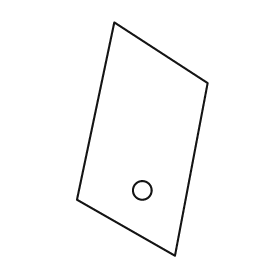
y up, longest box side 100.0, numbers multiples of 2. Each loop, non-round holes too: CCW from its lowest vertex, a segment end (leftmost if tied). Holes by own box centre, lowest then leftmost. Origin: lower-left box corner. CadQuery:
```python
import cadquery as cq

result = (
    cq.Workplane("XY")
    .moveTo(42.0, 0.0)
    .lineTo(56.0, 74.0)
    .lineTo(16.0, 100.0)
    .lineTo(0.0, 24.0)
    .close()
    .moveTo(28.0, 28.0)
    .circle(4.0)
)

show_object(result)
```